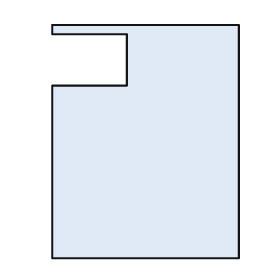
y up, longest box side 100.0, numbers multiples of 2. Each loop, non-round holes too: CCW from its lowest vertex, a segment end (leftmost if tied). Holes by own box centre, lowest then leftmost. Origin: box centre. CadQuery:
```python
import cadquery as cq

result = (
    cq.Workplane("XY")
    .moveTo(-40.0, -50.0)
    .lineTo(40.0, -50.0)
    .lineTo(40.0, 50.0)
    .lineTo(-40.0, 50.0)
    .lineTo(-40.0, 46.0)
    .lineTo(-8.0, 46.0)
    .lineTo(-8.0, 24.0)
    .lineTo(-40.0, 24.0)
    .close()
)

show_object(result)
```